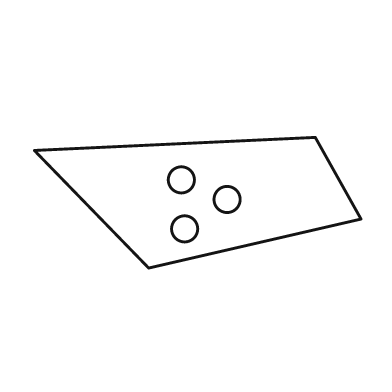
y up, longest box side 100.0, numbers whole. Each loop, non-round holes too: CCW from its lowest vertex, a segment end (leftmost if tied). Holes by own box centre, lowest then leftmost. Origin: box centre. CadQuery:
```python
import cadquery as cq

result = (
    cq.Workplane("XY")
    .moveTo(-15.0, -20.0)
    .lineTo(50.0, -5.0)
    .lineTo(36.0, 20.0)
    .lineTo(-50.0, 16.0)
    .close()
    .moveTo(-4.0, -8.0)
    .circle(4.0)
    .moveTo(9.0, 1.0)
    .circle(4.0)
    .moveTo(-5.0, 7.0)
    .circle(4.0)
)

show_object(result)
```